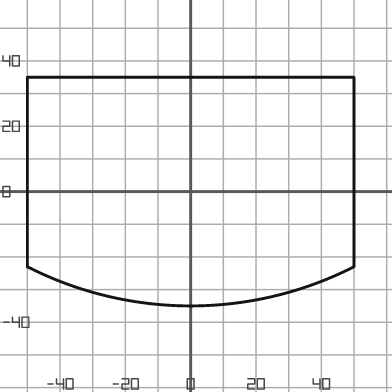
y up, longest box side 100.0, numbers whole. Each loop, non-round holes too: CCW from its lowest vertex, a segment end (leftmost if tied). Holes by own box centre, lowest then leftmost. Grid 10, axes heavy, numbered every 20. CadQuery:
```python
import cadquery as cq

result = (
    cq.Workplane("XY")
    .moveTo(-50.0, -23.0)
    .threePointArc((0.0, -35.0), (50.0, -23.0))
    .lineTo(50.0, 35.0)
    .lineTo(-50.0, 35.0)
    .close()
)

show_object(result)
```